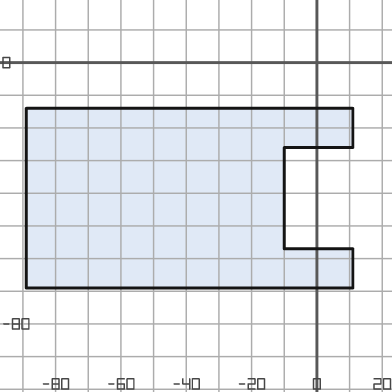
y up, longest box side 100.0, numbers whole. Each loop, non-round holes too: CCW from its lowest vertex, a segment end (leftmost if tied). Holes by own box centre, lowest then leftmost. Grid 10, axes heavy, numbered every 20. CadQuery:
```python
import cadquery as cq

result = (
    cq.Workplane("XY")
    .moveTo(-89.0, -69.0)
    .lineTo(11.0, -69.0)
    .lineTo(11.0, -57.0)
    .lineTo(-10.0, -57.0)
    .lineTo(-10.0, -26.0)
    .lineTo(11.0, -26.0)
    .lineTo(11.0, -14.0)
    .lineTo(-89.0, -14.0)
    .close()
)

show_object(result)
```